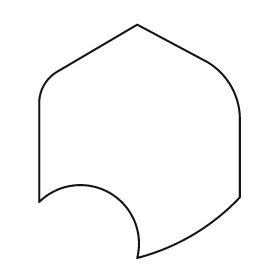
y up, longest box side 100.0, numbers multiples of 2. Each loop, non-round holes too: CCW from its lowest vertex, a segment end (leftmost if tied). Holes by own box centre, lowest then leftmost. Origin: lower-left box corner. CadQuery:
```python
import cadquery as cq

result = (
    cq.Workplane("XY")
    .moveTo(42.0, 0.0)
    .threePointArc((66.0, 10.0), (86.0, 26.0))
    .lineTo(86.0, 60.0)
    .threePointArc((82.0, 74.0), (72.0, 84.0))
    .lineTo(42.0, 100.0)
    .lineTo(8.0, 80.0)
    .threePointArc((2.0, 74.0), (0.0, 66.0))
    .lineTo(0.0, 24.0)
    .threePointArc((30.0, 28.0), (42.0, 0.0))
    .close()
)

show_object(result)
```